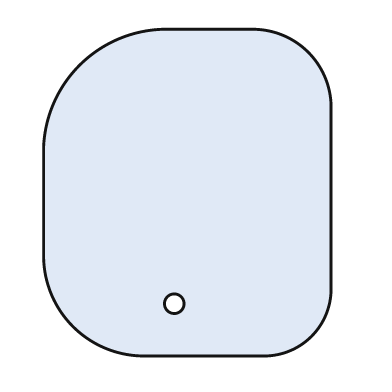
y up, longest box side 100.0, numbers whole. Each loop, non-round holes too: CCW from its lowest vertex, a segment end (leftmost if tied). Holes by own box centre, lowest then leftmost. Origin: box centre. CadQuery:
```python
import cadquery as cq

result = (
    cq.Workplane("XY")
    .moveTo(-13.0, -50.0)
    .lineTo(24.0, -50.0)
    .threePointArc((38.0, -44.0), (44.0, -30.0))
    .lineTo(44.0, 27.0)
    .threePointArc((37.0, 43.0), (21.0, 50.0))
    .lineTo(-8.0, 50.0)
    .threePointArc((-33.0, 39.0), (-44.0, 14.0))
    .lineTo(-44.0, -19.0)
    .threePointArc((-35.0, -41.0), (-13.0, -50.0))
    .close()
    .moveTo(-4.0, -34.0)
    .circle(3.0)
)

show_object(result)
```